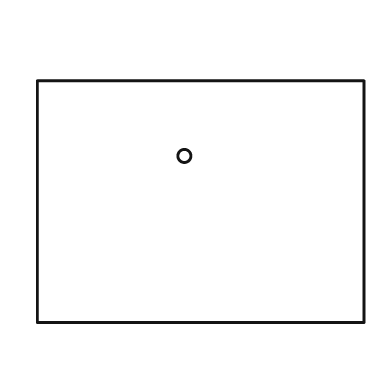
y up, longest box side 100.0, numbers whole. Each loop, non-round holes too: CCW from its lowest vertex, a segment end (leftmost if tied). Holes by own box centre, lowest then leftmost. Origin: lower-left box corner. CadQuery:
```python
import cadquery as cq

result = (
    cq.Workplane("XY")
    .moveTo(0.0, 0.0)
    .lineTo(100.0, 0.0)
    .lineTo(100.0, 74.0)
    .lineTo(0.0, 74.0)
    .close()
    .moveTo(45.0, 51.0)
    .circle(2.0)
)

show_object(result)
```